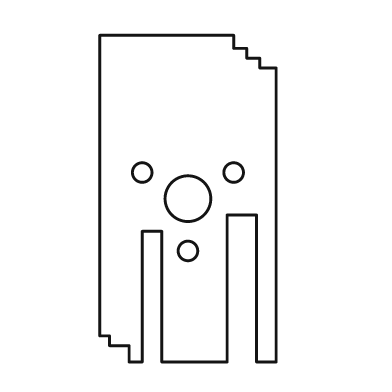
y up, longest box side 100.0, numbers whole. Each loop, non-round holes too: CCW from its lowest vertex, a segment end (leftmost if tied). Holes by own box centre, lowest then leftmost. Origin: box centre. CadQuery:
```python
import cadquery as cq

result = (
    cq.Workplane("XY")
    .moveTo(-18.0, -50.0)
    .lineTo(-14.0, -50.0)
    .lineTo(-14.0, -10.0)
    .lineTo(-8.0, -10.0)
    .lineTo(-8.0, -50.0)
    .lineTo(12.0, -50.0)
    .lineTo(12.0, -5.0)
    .lineTo(21.0, -5.0)
    .lineTo(21.0, -50.0)
    .lineTo(27.0, -50.0)
    .lineTo(27.0, 40.0)
    .lineTo(22.0, 40.0)
    .lineTo(22.0, 43.0)
    .lineTo(18.0, 43.0)
    .lineTo(18.0, 46.0)
    .lineTo(14.0, 46.0)
    .lineTo(14.0, 50.0)
    .lineTo(-27.0, 50.0)
    .lineTo(-27.0, -42.0)
    .lineTo(-24.0, -42.0)
    .lineTo(-24.0, -45.0)
    .lineTo(-18.0, -45.0)
    .close()
    .moveTo(0.0, -16.0)
    .circle(3.0)
    .moveTo(0.0, 0.0)
    .circle(7.0)
    .moveTo(-14.0, 8.0)
    .circle(3.0)
    .moveTo(14.0, 8.0)
    .circle(3.0)
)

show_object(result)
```